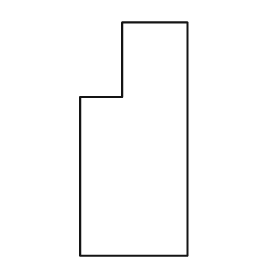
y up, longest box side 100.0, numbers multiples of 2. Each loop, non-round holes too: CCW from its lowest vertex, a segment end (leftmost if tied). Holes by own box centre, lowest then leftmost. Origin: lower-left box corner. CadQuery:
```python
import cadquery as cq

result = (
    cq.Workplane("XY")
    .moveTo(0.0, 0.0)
    .lineTo(46.0, 0.0)
    .lineTo(46.0, 100.0)
    .lineTo(18.0, 100.0)
    .lineTo(18.0, 68.0)
    .lineTo(0.0, 68.0)
    .close()
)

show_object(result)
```